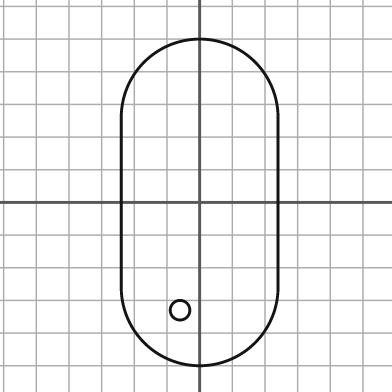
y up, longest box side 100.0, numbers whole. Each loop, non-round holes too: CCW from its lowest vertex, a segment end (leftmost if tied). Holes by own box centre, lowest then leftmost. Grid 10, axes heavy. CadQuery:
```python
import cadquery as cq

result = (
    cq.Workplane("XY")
    .moveTo(-24.0, -26.0)
    .threePointArc((0.0, -50.0), (24.0, -26.0))
    .lineTo(24.0, 26.0)
    .threePointArc((0.0, 50.0), (-24.0, 26.0))
    .close()
    .moveTo(-6.0, -33.0)
    .circle(3.0)
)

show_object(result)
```